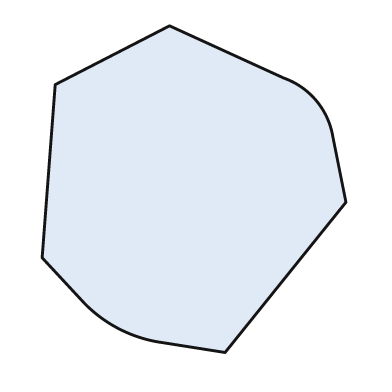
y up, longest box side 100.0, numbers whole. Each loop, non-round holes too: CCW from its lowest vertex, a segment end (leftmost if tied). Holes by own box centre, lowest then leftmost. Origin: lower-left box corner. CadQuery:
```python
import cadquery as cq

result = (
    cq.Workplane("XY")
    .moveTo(56.0, 0.0)
    .lineTo(93.0, 46.0)
    .lineTo(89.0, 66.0)
    .threePointArc((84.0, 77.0), (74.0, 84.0))
    .lineTo(39.0, 100.0)
    .lineTo(4.0, 82.0)
    .lineTo(0.0, 29.0)
    .lineTo(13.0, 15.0)
    .threePointArc((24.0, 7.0), (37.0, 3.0))
    .close()
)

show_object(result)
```